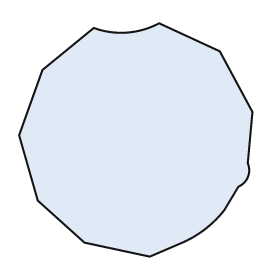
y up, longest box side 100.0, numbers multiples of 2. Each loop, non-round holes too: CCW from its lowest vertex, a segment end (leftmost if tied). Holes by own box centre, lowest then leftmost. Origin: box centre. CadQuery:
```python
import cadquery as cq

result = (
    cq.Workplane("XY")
    .moveTo(6.0, -50.0)
    .lineTo(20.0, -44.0)
    .threePointArc((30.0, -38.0), (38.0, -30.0))
    .lineTo(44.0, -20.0)
    .threePointArc((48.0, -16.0), (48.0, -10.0))
    .lineTo(50.0, 12.0)
    .lineTo(36.0, 38.0)
    .lineTo(10.0, 50.0)
    .threePointArc((-4.0, 46.0), (-18.0, 48.0))
    .lineTo(-40.0, 30.0)
    .lineTo(-50.0, 2.0)
    .lineTo(-42.0, -26.0)
    .lineTo(-22.0, -44.0)
    .close()
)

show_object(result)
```